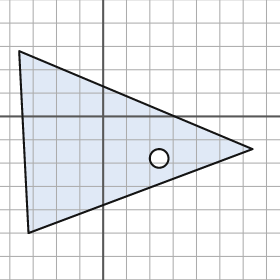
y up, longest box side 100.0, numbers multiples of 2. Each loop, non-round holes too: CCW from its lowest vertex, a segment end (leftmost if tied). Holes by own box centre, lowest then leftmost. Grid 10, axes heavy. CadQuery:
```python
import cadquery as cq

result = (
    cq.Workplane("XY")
    .moveTo(-32.0, -50.0)
    .lineTo(64.0, -14.0)
    .lineTo(-36.0, 28.0)
    .close()
    .moveTo(24.0, -18.0)
    .circle(4.0)
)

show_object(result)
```